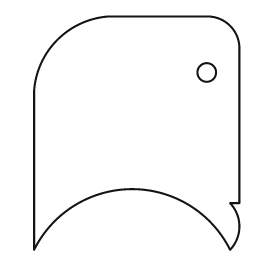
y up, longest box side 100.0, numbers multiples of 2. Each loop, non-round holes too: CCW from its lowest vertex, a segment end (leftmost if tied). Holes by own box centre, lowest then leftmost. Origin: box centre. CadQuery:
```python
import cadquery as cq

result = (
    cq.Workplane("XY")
    .moveTo(-44.0, -50.0)
    .threePointArc((-2.0, -24.0), (40.0, -50.0))
    .threePointArc((44.0, -40.0), (40.0, -30.0))
    .lineTo(44.0, -30.0)
    .lineTo(44.0, 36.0)
    .threePointArc((40.0, 46.0), (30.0, 50.0))
    .lineTo(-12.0, 50.0)
    .threePointArc((-34.0, 40.0), (-44.0, 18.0))
    .close()
    .moveTo(30.0, 26.0)
    .circle(4.0)
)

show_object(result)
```